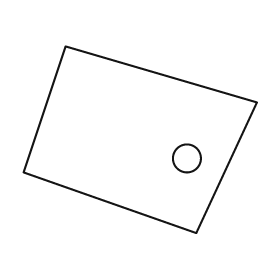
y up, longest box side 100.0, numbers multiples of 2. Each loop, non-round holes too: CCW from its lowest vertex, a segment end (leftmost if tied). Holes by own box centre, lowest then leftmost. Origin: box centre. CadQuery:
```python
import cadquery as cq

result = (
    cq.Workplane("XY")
    .moveTo(24.0, -40.0)
    .lineTo(50.0, 16.0)
    .lineTo(-32.0, 40.0)
    .lineTo(-50.0, -14.0)
    .close()
    .moveTo(20.0, -8.0)
    .circle(6.0)
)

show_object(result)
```